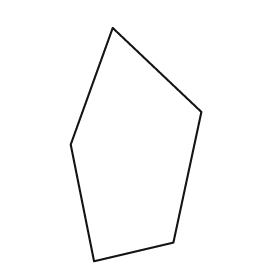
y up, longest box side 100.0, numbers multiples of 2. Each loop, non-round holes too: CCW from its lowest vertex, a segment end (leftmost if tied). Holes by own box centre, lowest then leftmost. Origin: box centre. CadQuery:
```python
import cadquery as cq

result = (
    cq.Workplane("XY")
    .moveTo(-18.0, -50.0)
    .lineTo(16.0, -42.0)
    .lineTo(28.0, 14.0)
    .lineTo(-10.0, 50.0)
    .lineTo(-28.0, 0.0)
    .close()
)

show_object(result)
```